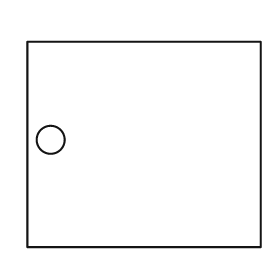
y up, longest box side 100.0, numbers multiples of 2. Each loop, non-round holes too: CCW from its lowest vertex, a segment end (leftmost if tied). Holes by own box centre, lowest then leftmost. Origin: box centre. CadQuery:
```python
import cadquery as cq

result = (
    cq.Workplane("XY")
    .moveTo(-50.0, -44.0)
    .lineTo(50.0, -44.0)
    .lineTo(50.0, 44.0)
    .lineTo(-50.0, 44.0)
    .close()
    .moveTo(-40.0, 2.0)
    .circle(6.0)
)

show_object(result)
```